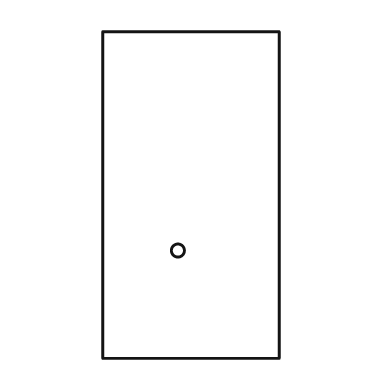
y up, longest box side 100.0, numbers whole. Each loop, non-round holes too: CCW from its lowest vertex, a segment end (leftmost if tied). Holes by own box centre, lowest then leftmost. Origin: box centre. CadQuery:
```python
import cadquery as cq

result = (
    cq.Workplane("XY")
    .moveTo(-27.0, -50.0)
    .lineTo(27.0, -50.0)
    .lineTo(27.0, 50.0)
    .lineTo(-27.0, 50.0)
    .close()
    .moveTo(-4.0, -17.0)
    .circle(2.0)
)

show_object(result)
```